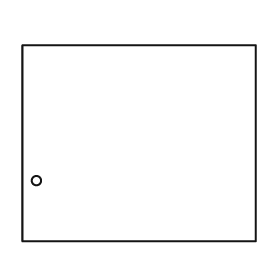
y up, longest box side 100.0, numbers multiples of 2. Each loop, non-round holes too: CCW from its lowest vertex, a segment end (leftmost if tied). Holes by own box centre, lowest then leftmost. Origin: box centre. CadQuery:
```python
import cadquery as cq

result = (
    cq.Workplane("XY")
    .moveTo(-50.0, -42.0)
    .lineTo(50.0, -42.0)
    .lineTo(50.0, 42.0)
    .lineTo(-50.0, 42.0)
    .close()
    .moveTo(-44.0, -16.0)
    .circle(2.0)
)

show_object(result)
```